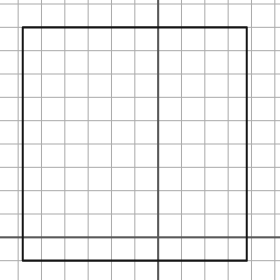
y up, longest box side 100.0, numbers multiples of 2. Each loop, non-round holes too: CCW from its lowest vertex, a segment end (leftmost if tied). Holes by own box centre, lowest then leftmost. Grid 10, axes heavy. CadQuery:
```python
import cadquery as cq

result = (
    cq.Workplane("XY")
    .moveTo(-58.0, -10.0)
    .lineTo(38.0, -10.0)
    .lineTo(38.0, 90.0)
    .lineTo(-58.0, 90.0)
    .close()
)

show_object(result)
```